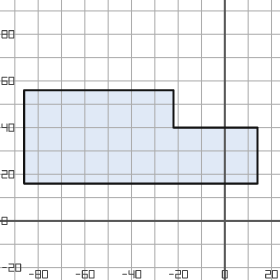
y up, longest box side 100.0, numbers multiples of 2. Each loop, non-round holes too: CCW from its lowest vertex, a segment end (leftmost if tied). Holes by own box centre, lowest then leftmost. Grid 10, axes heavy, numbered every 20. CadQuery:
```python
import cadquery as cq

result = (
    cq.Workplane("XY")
    .moveTo(-86.0, 16.0)
    .lineTo(14.0, 16.0)
    .lineTo(14.0, 40.0)
    .lineTo(-22.0, 40.0)
    .lineTo(-22.0, 56.0)
    .lineTo(-86.0, 56.0)
    .close()
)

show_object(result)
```